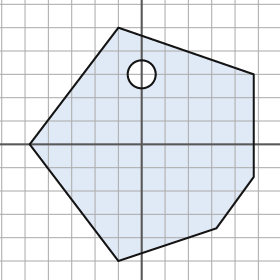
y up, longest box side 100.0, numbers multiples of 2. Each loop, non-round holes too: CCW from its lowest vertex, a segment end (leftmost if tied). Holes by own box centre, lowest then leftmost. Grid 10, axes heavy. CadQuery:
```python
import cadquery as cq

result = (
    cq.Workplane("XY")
    .moveTo(-10.0, -50.0)
    .lineTo(32.0, -36.0)
    .lineTo(48.0, -14.0)
    .lineTo(48.0, 30.0)
    .lineTo(-10.0, 50.0)
    .lineTo(-48.0, 0.0)
    .close()
    .moveTo(0.0, 30.0)
    .circle(6.0)
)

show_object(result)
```